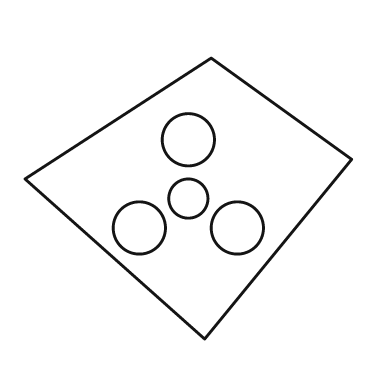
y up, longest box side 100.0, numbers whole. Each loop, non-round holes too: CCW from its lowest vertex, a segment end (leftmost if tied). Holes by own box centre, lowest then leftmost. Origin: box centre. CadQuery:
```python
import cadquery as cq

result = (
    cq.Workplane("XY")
    .moveTo(5.0, -43.0)
    .lineTo(50.0, 12.0)
    .lineTo(7.0, 43.0)
    .lineTo(-50.0, 6.0)
    .close()
    .moveTo(-15.0, -9.0)
    .circle(8.0)
    .moveTo(15.0, -9.0)
    .circle(8.0)
    .moveTo(0.0, 0.0)
    .circle(6.0)
    .moveTo(0.0, 18.0)
    .circle(8.0)
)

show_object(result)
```